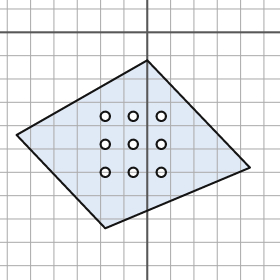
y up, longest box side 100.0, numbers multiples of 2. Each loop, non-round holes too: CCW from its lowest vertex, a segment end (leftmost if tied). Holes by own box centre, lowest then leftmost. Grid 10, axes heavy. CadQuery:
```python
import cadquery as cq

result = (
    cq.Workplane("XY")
    .moveTo(-18.0, -84.0)
    .lineTo(44.0, -58.0)
    .lineTo(0.0, -12.0)
    .lineTo(-56.0, -44.0)
    .close()
    .moveTo(-18.0, -60.0)
    .circle(2.0)
    .moveTo(-6.0, -60.0)
    .circle(2.0)
    .moveTo(6.0, -60.0)
    .circle(2.0)
    .moveTo(-18.0, -48.0)
    .circle(2.0)
    .moveTo(-6.0, -48.0)
    .circle(2.0)
    .moveTo(6.0, -48.0)
    .circle(2.0)
    .moveTo(-18.0, -36.0)
    .circle(2.0)
    .moveTo(-6.0, -36.0)
    .circle(2.0)
    .moveTo(6.0, -36.0)
    .circle(2.0)
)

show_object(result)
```